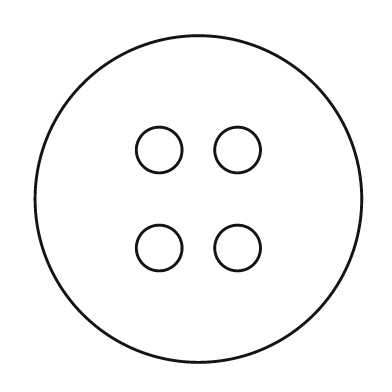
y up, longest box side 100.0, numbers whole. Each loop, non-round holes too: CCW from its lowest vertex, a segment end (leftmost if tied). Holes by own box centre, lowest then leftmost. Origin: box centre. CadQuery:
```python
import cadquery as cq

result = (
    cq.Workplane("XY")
    .moveTo(0.0, 0.0)
    .circle(50.0)
    .moveTo(-12.0, -15.0)
    .circle(7.0)
    .moveTo(12.0, -15.0)
    .circle(7.0)
    .moveTo(-12.0, 15.0)
    .circle(7.0)
    .moveTo(12.0, 15.0)
    .circle(7.0)
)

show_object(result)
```